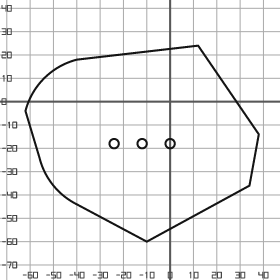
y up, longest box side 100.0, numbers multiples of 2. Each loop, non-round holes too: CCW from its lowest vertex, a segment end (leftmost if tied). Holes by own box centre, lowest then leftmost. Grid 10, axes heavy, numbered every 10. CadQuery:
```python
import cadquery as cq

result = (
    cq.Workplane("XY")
    .moveTo(-10.0, -60.0)
    .lineTo(34.0, -36.0)
    .lineTo(38.0, -14.0)
    .lineTo(12.0, 24.0)
    .lineTo(-40.0, 18.0)
    .threePointArc((-54.0, 10.0), (-62.0, -4.0))
    .lineTo(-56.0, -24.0)
    .threePointArc((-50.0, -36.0), (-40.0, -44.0))
    .close()
    .moveTo(-24.0, -18.0)
    .circle(2.0)
    .moveTo(-12.0, -18.0)
    .circle(2.0)
    .moveTo(0.0, -18.0)
    .circle(2.0)
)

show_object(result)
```